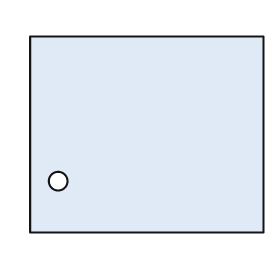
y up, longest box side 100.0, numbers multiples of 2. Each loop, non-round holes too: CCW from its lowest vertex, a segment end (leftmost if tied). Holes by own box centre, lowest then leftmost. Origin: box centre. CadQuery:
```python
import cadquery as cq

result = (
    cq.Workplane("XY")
    .moveTo(-50.0, -42.0)
    .lineTo(50.0, -42.0)
    .lineTo(50.0, 42.0)
    .lineTo(-50.0, 42.0)
    .close()
    .moveTo(-38.0, -20.0)
    .circle(4.0)
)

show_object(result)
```